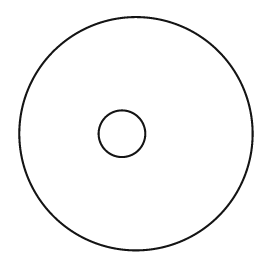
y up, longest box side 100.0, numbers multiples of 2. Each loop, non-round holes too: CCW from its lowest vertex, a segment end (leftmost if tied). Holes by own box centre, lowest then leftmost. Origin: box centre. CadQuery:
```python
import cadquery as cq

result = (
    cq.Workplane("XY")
    .moveTo(0.0, 0.0)
    .circle(50.0)
    .moveTo(-6.0, 0.0)
    .circle(10.0)
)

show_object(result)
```